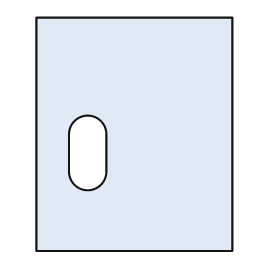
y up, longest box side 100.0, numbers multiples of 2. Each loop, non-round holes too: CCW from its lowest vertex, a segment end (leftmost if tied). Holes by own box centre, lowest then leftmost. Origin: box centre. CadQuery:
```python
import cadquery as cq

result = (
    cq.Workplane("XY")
    .moveTo(-42.0, -50.0)
    .lineTo(42.0, -50.0)
    .lineTo(42.0, 50.0)
    .lineTo(-42.0, 50.0)
    .close()
    .moveTo(-28.0, -16.0)
    .threePointArc((-20.0, -24.0), (-12.0, -16.0))
    .lineTo(-12.0, 0.0)
    .threePointArc((-20.0, 8.0), (-28.0, 0.0))
    .close()
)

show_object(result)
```